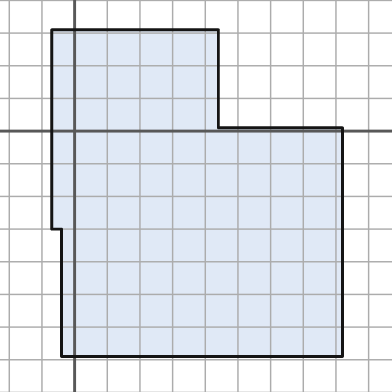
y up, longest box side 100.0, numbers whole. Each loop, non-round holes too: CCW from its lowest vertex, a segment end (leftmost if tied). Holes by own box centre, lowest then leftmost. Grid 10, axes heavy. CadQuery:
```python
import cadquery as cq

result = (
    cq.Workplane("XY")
    .moveTo(-4.0, -69.0)
    .lineTo(82.0, -69.0)
    .lineTo(82.0, 1.0)
    .lineTo(44.0, 1.0)
    .lineTo(44.0, 31.0)
    .lineTo(-7.0, 31.0)
    .lineTo(-7.0, -30.0)
    .lineTo(-4.0, -30.0)
    .close()
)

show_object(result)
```